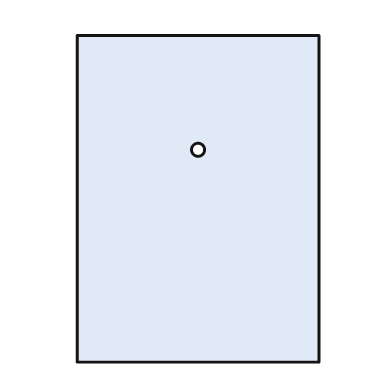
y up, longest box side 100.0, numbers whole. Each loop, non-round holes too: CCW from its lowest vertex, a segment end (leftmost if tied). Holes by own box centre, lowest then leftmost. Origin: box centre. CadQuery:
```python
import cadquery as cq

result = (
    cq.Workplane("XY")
    .moveTo(-37.0, -50.0)
    .lineTo(37.0, -50.0)
    .lineTo(37.0, 50.0)
    .lineTo(-37.0, 50.0)
    .close()
    .moveTo(0.0, 15.0)
    .circle(2.0)
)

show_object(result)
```